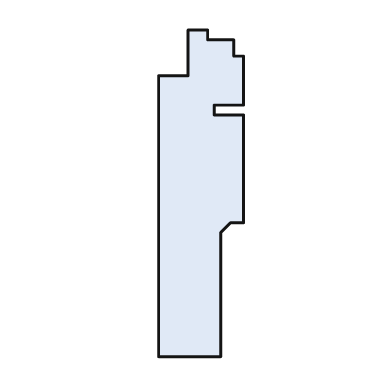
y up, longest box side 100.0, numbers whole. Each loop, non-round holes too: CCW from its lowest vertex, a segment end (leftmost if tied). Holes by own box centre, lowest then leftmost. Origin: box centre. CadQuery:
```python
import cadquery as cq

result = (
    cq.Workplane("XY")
    .moveTo(-13.0, -50.0)
    .lineTo(6.0, -50.0)
    .lineTo(6.0, -12.0)
    .lineTo(9.0, -9.0)
    .lineTo(13.0, -9.0)
    .lineTo(13.0, 24.0)
    .lineTo(4.0, 24.0)
    .lineTo(4.0, 27.0)
    .lineTo(13.0, 27.0)
    .lineTo(13.0, 42.0)
    .lineTo(10.0, 42.0)
    .lineTo(10.0, 47.0)
    .lineTo(2.0, 47.0)
    .lineTo(2.0, 50.0)
    .lineTo(-4.0, 50.0)
    .lineTo(-4.0, 36.0)
    .lineTo(-13.0, 36.0)
    .close()
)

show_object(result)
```